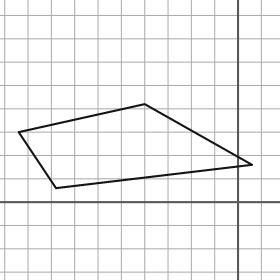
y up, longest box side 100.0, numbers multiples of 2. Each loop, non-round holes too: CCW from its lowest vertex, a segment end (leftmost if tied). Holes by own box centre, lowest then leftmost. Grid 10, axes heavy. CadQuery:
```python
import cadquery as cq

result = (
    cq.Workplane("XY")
    .moveTo(-78.0, 6.0)
    .lineTo(6.0, 16.0)
    .lineTo(-40.0, 42.0)
    .lineTo(-94.0, 30.0)
    .close()
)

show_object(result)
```